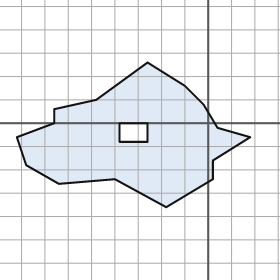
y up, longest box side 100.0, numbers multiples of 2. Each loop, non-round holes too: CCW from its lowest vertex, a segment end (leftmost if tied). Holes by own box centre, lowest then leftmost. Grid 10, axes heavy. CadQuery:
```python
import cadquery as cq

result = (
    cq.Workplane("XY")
    .moveTo(-18.0, -36.0)
    .lineTo(2.0, -24.0)
    .lineTo(2.0, -16.0)
    .lineTo(18.0, -6.0)
    .lineTo(4.0, -2.0)
    .lineTo(-2.0, 8.0)
    .lineTo(-10.0, 16.0)
    .lineTo(-26.0, 26.0)
    .lineTo(-48.0, 10.0)
    .lineTo(-66.0, 6.0)
    .lineTo(-66.0, 0.0)
    .lineTo(-82.0, -6.0)
    .lineTo(-78.0, -18.0)
    .lineTo(-64.0, -26.0)
    .lineTo(-40.0, -24.0)
    .close()
    .moveTo(-38.0, -8.0)
    .lineTo(-26.0, -8.0)
    .lineTo(-26.0, 0.0)
    .lineTo(-38.0, 0.0)
    .close()
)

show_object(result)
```